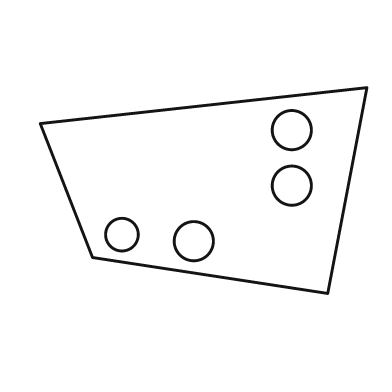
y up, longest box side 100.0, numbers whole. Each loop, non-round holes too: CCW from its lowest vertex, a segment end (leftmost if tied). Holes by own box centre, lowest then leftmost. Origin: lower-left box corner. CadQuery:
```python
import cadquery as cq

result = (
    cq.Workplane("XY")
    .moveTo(88.0, 0.0)
    .lineTo(100.0, 63.0)
    .lineTo(0.0, 52.0)
    .lineTo(16.0, 11.0)
    .close()
    .moveTo(47.0, 16.0)
    .circle(6.0)
    .moveTo(25.0, 18.0)
    .circle(5.0)
    .moveTo(77.0, 33.0)
    .circle(6.0)
    .moveTo(77.0, 50.0)
    .circle(6.0)
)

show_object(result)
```